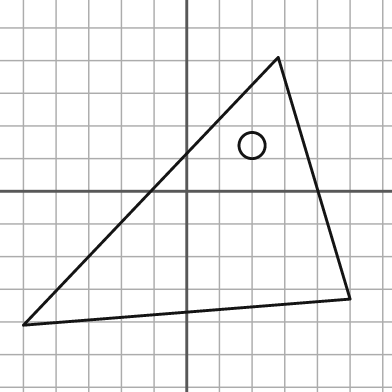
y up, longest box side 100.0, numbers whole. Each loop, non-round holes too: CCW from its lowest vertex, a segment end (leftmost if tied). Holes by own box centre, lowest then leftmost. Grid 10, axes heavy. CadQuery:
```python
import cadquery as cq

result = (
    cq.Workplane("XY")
    .moveTo(-50.0, -41.0)
    .lineTo(50.0, -33.0)
    .lineTo(28.0, 41.0)
    .close()
    .moveTo(20.0, 14.0)
    .circle(4.0)
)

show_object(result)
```